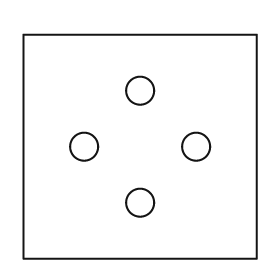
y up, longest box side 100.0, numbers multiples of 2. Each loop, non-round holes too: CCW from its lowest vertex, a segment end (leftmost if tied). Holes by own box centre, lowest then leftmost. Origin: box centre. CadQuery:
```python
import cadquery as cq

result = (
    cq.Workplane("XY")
    .moveTo(-50.0, -48.0)
    .lineTo(50.0, -48.0)
    .lineTo(50.0, 48.0)
    .lineTo(-50.0, 48.0)
    .close()
    .moveTo(0.0, -24.0)
    .circle(6.0)
    .moveTo(-24.0, 0.0)
    .circle(6.0)
    .moveTo(24.0, 0.0)
    .circle(6.0)
    .moveTo(0.0, 24.0)
    .circle(6.0)
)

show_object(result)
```